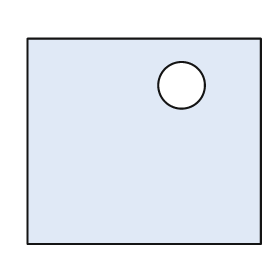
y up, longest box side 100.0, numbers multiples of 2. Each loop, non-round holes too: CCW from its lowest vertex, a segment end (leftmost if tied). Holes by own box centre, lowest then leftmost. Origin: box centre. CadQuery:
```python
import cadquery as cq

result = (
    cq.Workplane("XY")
    .moveTo(-50.0, -44.0)
    .lineTo(50.0, -44.0)
    .lineTo(50.0, 44.0)
    .lineTo(-50.0, 44.0)
    .close()
    .moveTo(16.0, 24.0)
    .circle(10.0)
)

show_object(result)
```